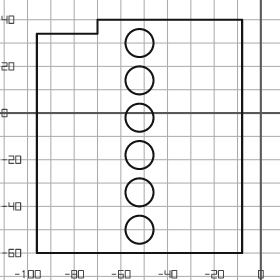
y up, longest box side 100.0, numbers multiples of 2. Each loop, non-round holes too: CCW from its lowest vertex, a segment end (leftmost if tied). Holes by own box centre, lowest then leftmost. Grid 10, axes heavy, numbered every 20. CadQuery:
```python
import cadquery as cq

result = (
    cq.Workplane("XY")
    .moveTo(-96.0, -60.0)
    .lineTo(-8.0, -60.0)
    .lineTo(-8.0, 40.0)
    .lineTo(-70.0, 40.0)
    .lineTo(-70.0, 34.0)
    .lineTo(-96.0, 34.0)
    .close()
    .moveTo(-52.0, -50.0)
    .circle(6.0)
    .moveTo(-52.0, -34.0)
    .circle(6.0)
    .moveTo(-52.0, -18.0)
    .circle(6.0)
    .moveTo(-52.0, -2.0)
    .circle(6.0)
    .moveTo(-52.0, 14.0)
    .circle(6.0)
    .moveTo(-52.0, 30.0)
    .circle(6.0)
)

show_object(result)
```